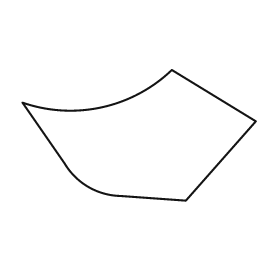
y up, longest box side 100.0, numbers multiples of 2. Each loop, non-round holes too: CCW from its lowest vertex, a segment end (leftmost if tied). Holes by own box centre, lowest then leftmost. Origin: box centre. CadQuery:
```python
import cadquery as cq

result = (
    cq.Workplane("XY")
    .moveTo(20.0, -28.0)
    .lineTo(50.0, 6.0)
    .lineTo(14.0, 28.0)
    .threePointArc((-16.0, 12.0), (-50.0, 14.0))
    .lineTo(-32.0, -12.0)
    .threePointArc((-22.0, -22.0), (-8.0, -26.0))
    .close()
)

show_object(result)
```